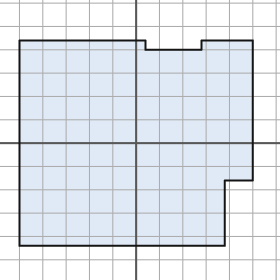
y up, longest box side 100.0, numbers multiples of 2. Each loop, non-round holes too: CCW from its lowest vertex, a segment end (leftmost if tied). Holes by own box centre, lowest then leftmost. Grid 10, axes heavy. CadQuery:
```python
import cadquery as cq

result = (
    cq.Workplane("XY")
    .moveTo(-50.0, -44.0)
    .lineTo(38.0, -44.0)
    .lineTo(38.0, -16.0)
    .lineTo(50.0, -16.0)
    .lineTo(50.0, 44.0)
    .lineTo(28.0, 44.0)
    .lineTo(28.0, 40.0)
    .lineTo(4.0, 40.0)
    .lineTo(4.0, 44.0)
    .lineTo(-50.0, 44.0)
    .close()
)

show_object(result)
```